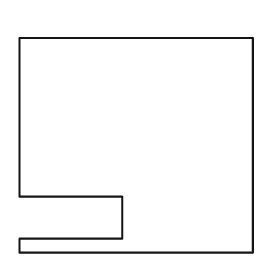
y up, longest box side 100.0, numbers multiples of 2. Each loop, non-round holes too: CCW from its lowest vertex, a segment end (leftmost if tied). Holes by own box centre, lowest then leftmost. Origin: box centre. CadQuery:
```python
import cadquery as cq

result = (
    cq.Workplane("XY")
    .moveTo(-50.0, -46.0)
    .lineTo(50.0, -46.0)
    .lineTo(50.0, 46.0)
    .lineTo(-50.0, 46.0)
    .lineTo(-50.0, -22.0)
    .lineTo(-6.0, -22.0)
    .lineTo(-6.0, -40.0)
    .lineTo(-50.0, -40.0)
    .close()
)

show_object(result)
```